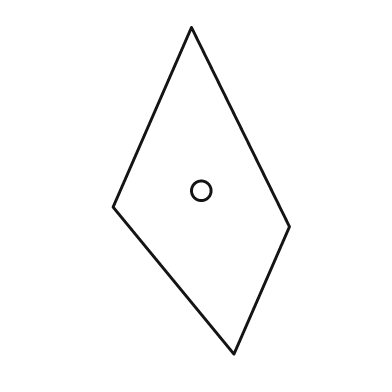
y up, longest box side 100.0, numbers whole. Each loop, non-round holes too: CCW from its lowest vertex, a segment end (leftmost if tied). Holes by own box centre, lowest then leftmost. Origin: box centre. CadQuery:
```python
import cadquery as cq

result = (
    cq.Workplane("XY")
    .moveTo(10.0, -50.0)
    .lineTo(27.0, -11.0)
    .lineTo(-3.0, 50.0)
    .lineTo(-27.0, -5.0)
    .close()
    .moveTo(0.0, 0.0)
    .circle(3.0)
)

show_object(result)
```